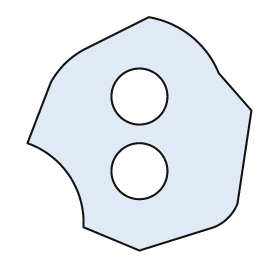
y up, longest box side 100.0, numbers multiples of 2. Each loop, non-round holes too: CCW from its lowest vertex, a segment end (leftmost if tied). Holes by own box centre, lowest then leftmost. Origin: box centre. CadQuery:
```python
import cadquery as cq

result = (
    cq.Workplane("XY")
    .moveTo(0.0, -50.0)
    .lineTo(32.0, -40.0)
    .threePointArc((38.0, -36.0), (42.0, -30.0))
    .lineTo(48.0, 10.0)
    .lineTo(34.0, 26.0)
    .threePointArc((22.0, 42.0), (4.0, 50.0))
    .lineTo(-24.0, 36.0)
    .threePointArc((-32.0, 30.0), (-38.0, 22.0))
    .lineTo(-48.0, -4.0)
    .threePointArc((-30.0, -18.0), (-24.0, -40.0))
    .close()
    .moveTo(0.0, -16.0)
    .circle(12.0)
    .moveTo(0.0, 16.0)
    .circle(12.0)
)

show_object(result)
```